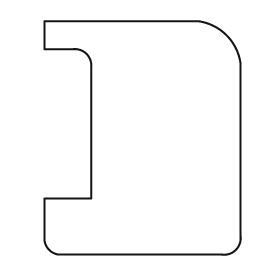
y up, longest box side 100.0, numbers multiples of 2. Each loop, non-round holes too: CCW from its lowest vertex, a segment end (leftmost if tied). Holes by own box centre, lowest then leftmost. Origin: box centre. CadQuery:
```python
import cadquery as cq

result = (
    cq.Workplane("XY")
    .moveTo(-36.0, -50.0)
    .lineTo(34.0, -50.0)
    .threePointArc((40.0, -48.0), (42.0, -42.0))
    .lineTo(42.0, 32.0)
    .threePointArc((36.0, 44.0), (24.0, 50.0))
    .lineTo(-42.0, 50.0)
    .lineTo(-42.0, 38.0)
    .lineTo(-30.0, 38.0)
    .threePointArc((-24.0, 36.0), (-22.0, 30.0))
    .lineTo(-22.0, -26.0)
    .lineTo(-42.0, -26.0)
    .lineTo(-42.0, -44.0)
    .threePointArc((-40.0, -48.0), (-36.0, -50.0))
    .close()
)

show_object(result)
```